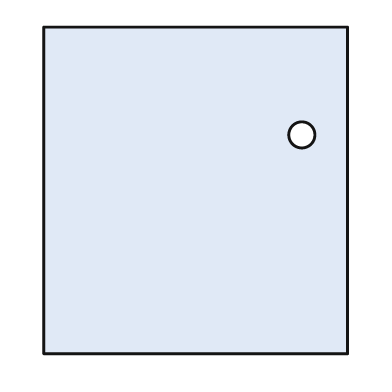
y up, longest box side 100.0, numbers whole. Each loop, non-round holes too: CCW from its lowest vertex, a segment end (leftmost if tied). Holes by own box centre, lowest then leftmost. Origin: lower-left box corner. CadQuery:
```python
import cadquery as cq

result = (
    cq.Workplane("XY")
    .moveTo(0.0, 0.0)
    .lineTo(93.0, 0.0)
    .lineTo(93.0, 100.0)
    .lineTo(0.0, 100.0)
    .close()
    .moveTo(79.0, 67.0)
    .circle(4.0)
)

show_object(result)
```